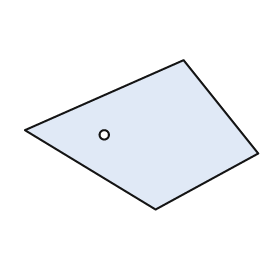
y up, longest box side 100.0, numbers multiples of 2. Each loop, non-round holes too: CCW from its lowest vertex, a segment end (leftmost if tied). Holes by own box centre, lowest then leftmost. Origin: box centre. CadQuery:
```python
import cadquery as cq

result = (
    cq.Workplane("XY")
    .moveTo(6.0, -32.0)
    .lineTo(50.0, -8.0)
    .lineTo(18.0, 32.0)
    .lineTo(-50.0, 2.0)
    .close()
    .moveTo(-16.0, 0.0)
    .circle(2.0)
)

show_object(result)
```